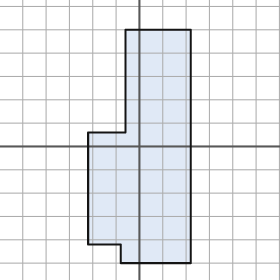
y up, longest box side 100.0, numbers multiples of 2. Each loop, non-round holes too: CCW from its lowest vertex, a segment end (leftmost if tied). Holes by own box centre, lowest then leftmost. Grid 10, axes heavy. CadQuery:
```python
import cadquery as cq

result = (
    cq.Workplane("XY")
    .moveTo(-8.0, -50.0)
    .lineTo(22.0, -50.0)
    .lineTo(22.0, 50.0)
    .lineTo(-6.0, 50.0)
    .lineTo(-6.0, 6.0)
    .lineTo(-22.0, 6.0)
    .lineTo(-22.0, -42.0)
    .lineTo(-8.0, -42.0)
    .close()
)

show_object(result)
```